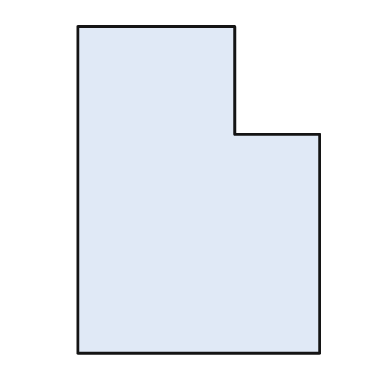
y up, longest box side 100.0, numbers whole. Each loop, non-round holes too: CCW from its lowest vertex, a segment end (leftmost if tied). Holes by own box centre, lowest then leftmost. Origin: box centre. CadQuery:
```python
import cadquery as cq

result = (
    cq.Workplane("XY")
    .moveTo(-37.0, -50.0)
    .lineTo(37.0, -50.0)
    .lineTo(37.0, 17.0)
    .lineTo(11.0, 17.0)
    .lineTo(11.0, 50.0)
    .lineTo(-37.0, 50.0)
    .close()
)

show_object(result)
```